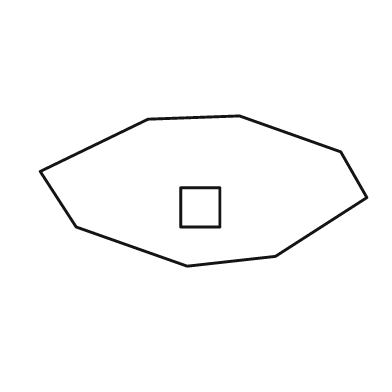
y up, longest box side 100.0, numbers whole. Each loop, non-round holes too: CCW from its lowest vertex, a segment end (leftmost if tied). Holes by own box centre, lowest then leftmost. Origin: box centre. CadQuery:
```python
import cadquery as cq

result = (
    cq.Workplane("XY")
    .moveTo(-5.0, -23.0)
    .lineTo(22.0, -20.0)
    .lineTo(50.0, -2.0)
    .lineTo(42.0, 12.0)
    .lineTo(11.0, 23.0)
    .lineTo(-17.0, 22.0)
    .lineTo(-50.0, 6.0)
    .lineTo(-39.0, -11.0)
    .close()
    .moveTo(-7.0, -11.0)
    .lineTo(5.0, -11.0)
    .lineTo(5.0, 1.0)
    .lineTo(-7.0, 1.0)
    .close()
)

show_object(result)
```